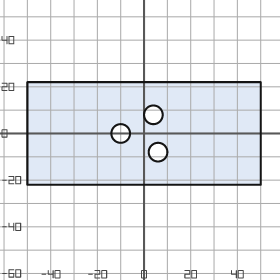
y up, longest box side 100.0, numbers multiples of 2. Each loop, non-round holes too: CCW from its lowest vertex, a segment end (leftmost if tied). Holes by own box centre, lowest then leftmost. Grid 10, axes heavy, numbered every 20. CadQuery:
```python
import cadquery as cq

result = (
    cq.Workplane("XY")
    .moveTo(-50.0, -22.0)
    .lineTo(50.0, -22.0)
    .lineTo(50.0, 22.0)
    .lineTo(-50.0, 22.0)
    .close()
    .moveTo(6.0, -8.0)
    .circle(4.0)
    .moveTo(-10.0, 0.0)
    .circle(4.0)
    .moveTo(4.0, 8.0)
    .circle(4.0)
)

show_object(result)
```